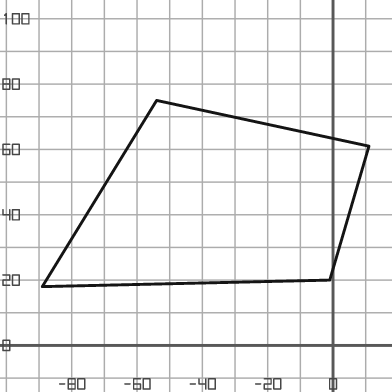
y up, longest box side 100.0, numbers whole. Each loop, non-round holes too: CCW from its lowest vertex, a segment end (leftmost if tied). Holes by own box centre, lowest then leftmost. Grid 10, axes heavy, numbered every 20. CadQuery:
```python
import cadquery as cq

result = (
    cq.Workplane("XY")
    .moveTo(-89.0, 18.0)
    .lineTo(-1.0, 20.0)
    .lineTo(11.0, 61.0)
    .lineTo(-54.0, 75.0)
    .close()
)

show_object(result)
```